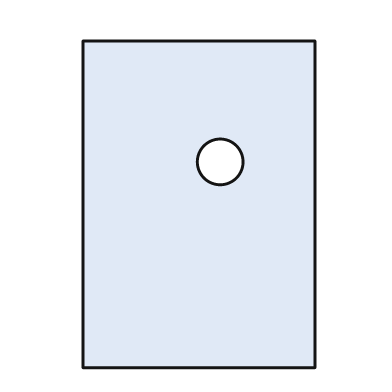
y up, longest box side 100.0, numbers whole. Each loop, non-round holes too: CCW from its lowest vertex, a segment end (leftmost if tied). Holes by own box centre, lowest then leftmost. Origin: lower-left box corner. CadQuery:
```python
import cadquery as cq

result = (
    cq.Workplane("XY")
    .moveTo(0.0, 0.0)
    .lineTo(71.0, 0.0)
    .lineTo(71.0, 100.0)
    .lineTo(0.0, 100.0)
    .close()
    .moveTo(42.0, 63.0)
    .circle(7.0)
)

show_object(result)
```